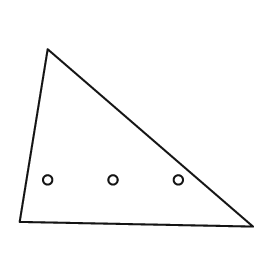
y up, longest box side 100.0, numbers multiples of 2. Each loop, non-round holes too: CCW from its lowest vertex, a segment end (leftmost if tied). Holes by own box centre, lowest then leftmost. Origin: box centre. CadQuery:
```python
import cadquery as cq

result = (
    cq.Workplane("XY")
    .moveTo(50.0, -38.0)
    .lineTo(-38.0, 38.0)
    .lineTo(-50.0, -36.0)
    .close()
    .moveTo(-38.0, -18.0)
    .circle(2.0)
    .moveTo(-10.0, -18.0)
    .circle(2.0)
    .moveTo(18.0, -18.0)
    .circle(2.0)
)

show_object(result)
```